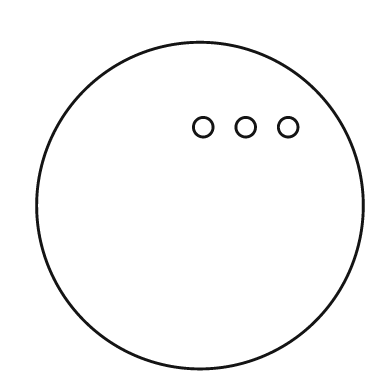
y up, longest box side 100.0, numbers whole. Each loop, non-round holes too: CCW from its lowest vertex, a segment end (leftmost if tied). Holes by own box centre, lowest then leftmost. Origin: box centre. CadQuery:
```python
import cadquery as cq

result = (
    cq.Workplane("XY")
    .moveTo(0.0, 0.0)
    .circle(50.0)
    .moveTo(1.0, 24.0)
    .circle(3.0)
    .moveTo(14.0, 24.0)
    .circle(3.0)
    .moveTo(27.0, 24.0)
    .circle(3.0)
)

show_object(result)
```